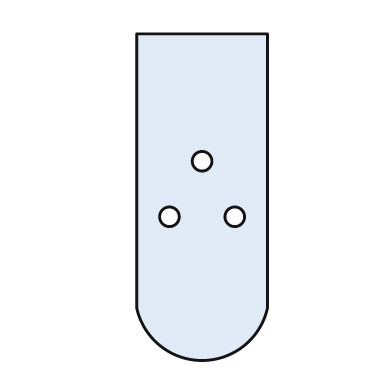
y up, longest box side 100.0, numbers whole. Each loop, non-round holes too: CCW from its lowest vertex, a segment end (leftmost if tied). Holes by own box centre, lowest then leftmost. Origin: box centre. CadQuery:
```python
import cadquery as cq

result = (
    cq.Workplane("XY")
    .moveTo(-20.0, -34.0)
    .threePointArc((0.0, -50.0), (20.0, -34.0))
    .lineTo(20.0, 50.0)
    .lineTo(-20.0, 50.0)
    .close()
    .moveTo(-10.0, -6.0)
    .circle(3.0)
    .moveTo(10.0, -6.0)
    .circle(3.0)
    .moveTo(0.0, 11.0)
    .circle(3.0)
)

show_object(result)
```